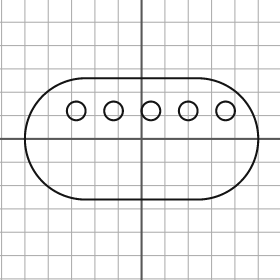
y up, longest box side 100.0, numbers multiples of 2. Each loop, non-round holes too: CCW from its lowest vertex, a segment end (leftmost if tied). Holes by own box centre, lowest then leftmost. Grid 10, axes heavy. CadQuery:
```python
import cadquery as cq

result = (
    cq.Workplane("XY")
    .moveTo(-24.0, -26.0)
    .lineTo(24.0, -26.0)
    .threePointArc((50.0, 0.0), (24.0, 26.0))
    .lineTo(-24.0, 26.0)
    .threePointArc((-50.0, 0.0), (-24.0, -26.0))
    .close()
    .moveTo(-28.0, 12.0)
    .circle(4.0)
    .moveTo(-12.0, 12.0)
    .circle(4.0)
    .moveTo(4.0, 12.0)
    .circle(4.0)
    .moveTo(20.0, 12.0)
    .circle(4.0)
    .moveTo(36.0, 12.0)
    .circle(4.0)
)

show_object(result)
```